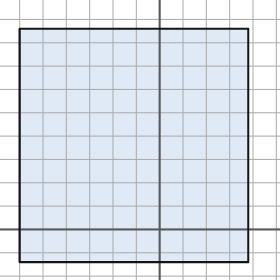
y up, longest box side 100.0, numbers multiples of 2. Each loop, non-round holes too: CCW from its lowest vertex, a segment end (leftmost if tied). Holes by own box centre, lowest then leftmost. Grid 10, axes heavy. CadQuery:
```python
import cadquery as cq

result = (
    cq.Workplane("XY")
    .moveTo(-60.0, -14.0)
    .lineTo(38.0, -14.0)
    .lineTo(38.0, 86.0)
    .lineTo(-60.0, 86.0)
    .close()
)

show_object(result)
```